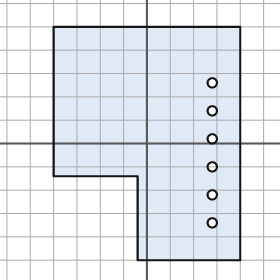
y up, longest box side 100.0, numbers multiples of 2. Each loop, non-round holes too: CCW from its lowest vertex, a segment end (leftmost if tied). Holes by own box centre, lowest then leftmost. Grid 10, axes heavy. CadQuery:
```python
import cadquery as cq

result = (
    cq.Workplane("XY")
    .moveTo(-4.0, -50.0)
    .lineTo(40.0, -50.0)
    .lineTo(40.0, 50.0)
    .lineTo(-40.0, 50.0)
    .lineTo(-40.0, -14.0)
    .lineTo(-4.0, -14.0)
    .close()
    .moveTo(28.0, -34.0)
    .circle(2.0)
    .moveTo(28.0, -22.0)
    .circle(2.0)
    .moveTo(28.0, -10.0)
    .circle(2.0)
    .moveTo(28.0, 2.0)
    .circle(2.0)
    .moveTo(28.0, 14.0)
    .circle(2.0)
    .moveTo(28.0, 26.0)
    .circle(2.0)
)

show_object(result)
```